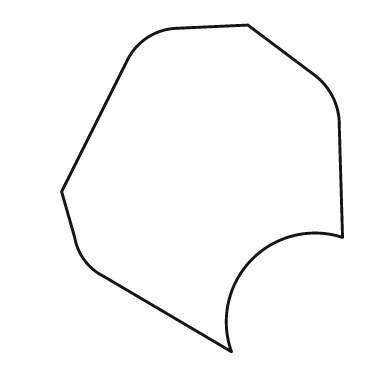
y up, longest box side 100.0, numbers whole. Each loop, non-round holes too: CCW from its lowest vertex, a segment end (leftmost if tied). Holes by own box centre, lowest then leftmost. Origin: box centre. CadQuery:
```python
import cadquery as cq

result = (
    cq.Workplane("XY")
    .moveTo(9.0, -50.0)
    .threePointArc((15.0, -22.0), (43.0, -15.0))
    .lineTo(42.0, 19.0)
    .threePointArc((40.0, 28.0), (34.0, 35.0))
    .lineTo(14.0, 50.0)
    .lineTo(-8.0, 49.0)
    .threePointArc((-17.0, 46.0), (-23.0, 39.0))
    .lineTo(-43.0, -1.0)
    .lineTo(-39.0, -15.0)
    .threePointArc((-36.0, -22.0), (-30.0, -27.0))
    .close()
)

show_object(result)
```